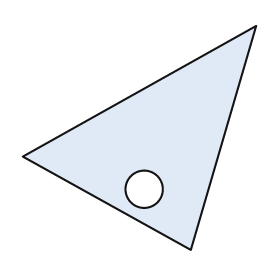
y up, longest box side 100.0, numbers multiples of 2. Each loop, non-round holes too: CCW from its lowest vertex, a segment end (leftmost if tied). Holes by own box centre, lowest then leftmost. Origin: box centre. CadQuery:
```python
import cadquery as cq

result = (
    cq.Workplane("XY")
    .moveTo(22.0, -48.0)
    .lineTo(50.0, 48.0)
    .lineTo(-50.0, -8.0)
    .close()
    .moveTo(2.0, -22.0)
    .circle(8.0)
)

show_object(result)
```